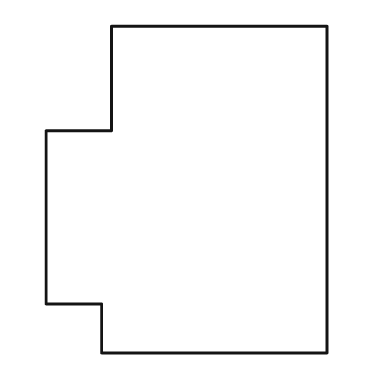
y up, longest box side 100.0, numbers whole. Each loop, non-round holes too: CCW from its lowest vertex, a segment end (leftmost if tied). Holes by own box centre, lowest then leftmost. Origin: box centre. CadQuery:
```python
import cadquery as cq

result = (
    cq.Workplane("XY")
    .moveTo(-26.0, -50.0)
    .lineTo(43.0, -50.0)
    .lineTo(43.0, 50.0)
    .lineTo(-23.0, 50.0)
    .lineTo(-23.0, 18.0)
    .lineTo(-43.0, 18.0)
    .lineTo(-43.0, -35.0)
    .lineTo(-26.0, -35.0)
    .close()
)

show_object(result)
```